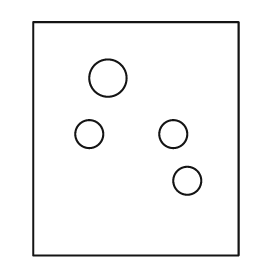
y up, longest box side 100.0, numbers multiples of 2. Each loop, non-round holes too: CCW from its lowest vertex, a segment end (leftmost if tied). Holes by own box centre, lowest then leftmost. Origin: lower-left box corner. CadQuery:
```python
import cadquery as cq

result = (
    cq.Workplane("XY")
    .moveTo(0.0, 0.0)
    .lineTo(88.0, 0.0)
    .lineTo(88.0, 100.0)
    .lineTo(0.0, 100.0)
    .close()
    .moveTo(66.0, 32.0)
    .circle(6.0)
    .moveTo(24.0, 52.0)
    .circle(6.0)
    .moveTo(60.0, 52.0)
    .circle(6.0)
    .moveTo(32.0, 76.0)
    .circle(8.0)
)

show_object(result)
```